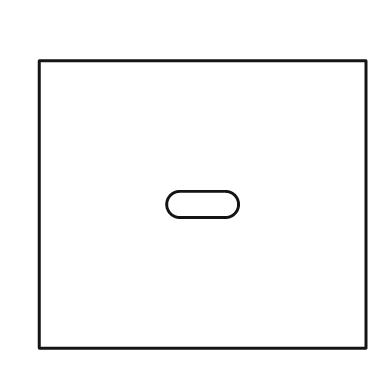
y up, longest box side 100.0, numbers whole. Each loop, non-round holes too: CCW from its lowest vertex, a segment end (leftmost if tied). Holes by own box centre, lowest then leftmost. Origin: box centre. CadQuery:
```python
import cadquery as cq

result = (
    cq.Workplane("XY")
    .moveTo(-50.0, -44.0)
    .lineTo(50.0, -44.0)
    .lineTo(50.0, 44.0)
    .lineTo(-50.0, 44.0)
    .close()
    .moveTo(-7.0, -4.0)
    .lineTo(7.0, -4.0)
    .threePointArc((11.0, 0.0), (7.0, 4.0))
    .lineTo(-7.0, 4.0)
    .threePointArc((-11.0, 0.0), (-7.0, -4.0))
    .close()
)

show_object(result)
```